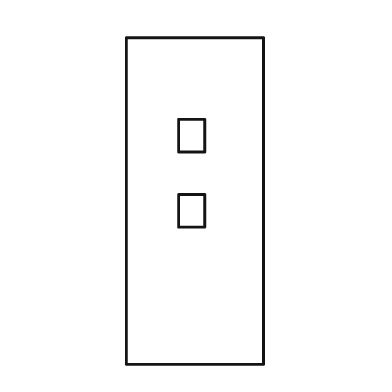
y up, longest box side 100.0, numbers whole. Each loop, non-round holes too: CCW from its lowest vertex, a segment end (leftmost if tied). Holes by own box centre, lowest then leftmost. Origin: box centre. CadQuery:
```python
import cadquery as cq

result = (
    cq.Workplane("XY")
    .moveTo(-21.0, -50.0)
    .lineTo(21.0, -50.0)
    .lineTo(21.0, 50.0)
    .lineTo(-21.0, 50.0)
    .close()
    .moveTo(-5.0, -8.0)
    .lineTo(3.0, -8.0)
    .lineTo(3.0, 2.0)
    .lineTo(-5.0, 2.0)
    .close()
    .moveTo(-5.0, 15.0)
    .lineTo(3.0, 15.0)
    .lineTo(3.0, 25.0)
    .lineTo(-5.0, 25.0)
    .close()
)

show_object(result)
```